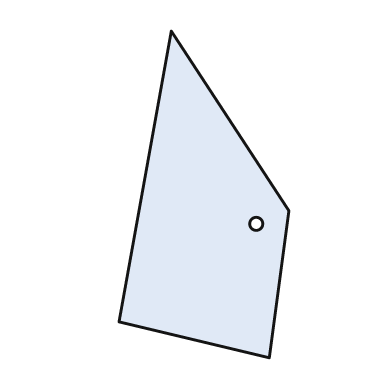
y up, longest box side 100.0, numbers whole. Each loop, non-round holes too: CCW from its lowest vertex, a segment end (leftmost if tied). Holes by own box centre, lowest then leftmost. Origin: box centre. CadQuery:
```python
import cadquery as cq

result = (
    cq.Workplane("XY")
    .moveTo(20.0, -50.0)
    .lineTo(26.0, -5.0)
    .lineTo(-10.0, 50.0)
    .lineTo(-26.0, -39.0)
    .close()
    .moveTo(16.0, -9.0)
    .circle(2.0)
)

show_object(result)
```